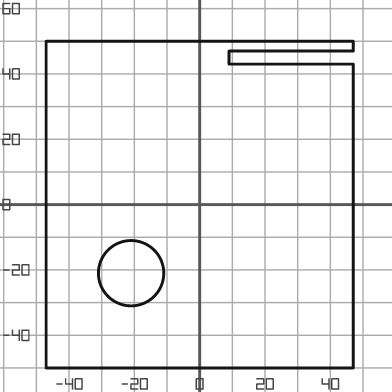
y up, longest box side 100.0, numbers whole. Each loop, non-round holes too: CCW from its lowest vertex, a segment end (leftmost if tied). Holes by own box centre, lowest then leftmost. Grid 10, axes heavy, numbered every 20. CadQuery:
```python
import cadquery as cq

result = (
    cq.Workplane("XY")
    .moveTo(-47.0, -50.0)
    .lineTo(47.0, -50.0)
    .lineTo(47.0, 43.0)
    .lineTo(9.0, 43.0)
    .lineTo(9.0, 47.0)
    .lineTo(47.0, 47.0)
    .lineTo(47.0, 50.0)
    .lineTo(-47.0, 50.0)
    .close()
    .moveTo(-21.0, -21.0)
    .circle(10.0)
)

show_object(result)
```